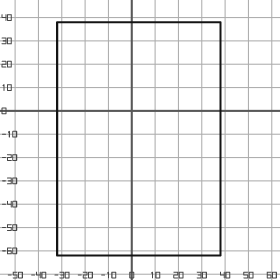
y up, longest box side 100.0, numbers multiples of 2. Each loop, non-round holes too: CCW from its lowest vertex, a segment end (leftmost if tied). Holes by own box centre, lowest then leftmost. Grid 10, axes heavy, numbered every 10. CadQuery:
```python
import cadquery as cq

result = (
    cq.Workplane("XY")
    .moveTo(-32.0, -62.0)
    .lineTo(38.0, -62.0)
    .lineTo(38.0, 38.0)
    .lineTo(-32.0, 38.0)
    .close()
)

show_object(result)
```